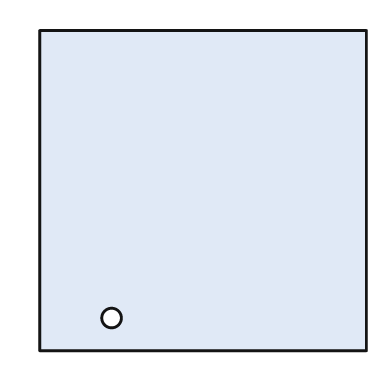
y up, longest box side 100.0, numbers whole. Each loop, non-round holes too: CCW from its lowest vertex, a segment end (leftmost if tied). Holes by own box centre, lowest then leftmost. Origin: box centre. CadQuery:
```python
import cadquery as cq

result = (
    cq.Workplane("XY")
    .moveTo(-50.0, -49.0)
    .lineTo(50.0, -49.0)
    .lineTo(50.0, 49.0)
    .lineTo(-50.0, 49.0)
    .close()
    .moveTo(-28.0, -39.0)
    .circle(3.0)
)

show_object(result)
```